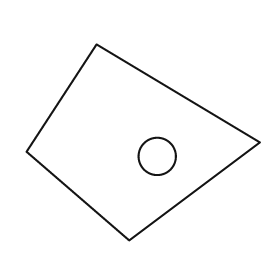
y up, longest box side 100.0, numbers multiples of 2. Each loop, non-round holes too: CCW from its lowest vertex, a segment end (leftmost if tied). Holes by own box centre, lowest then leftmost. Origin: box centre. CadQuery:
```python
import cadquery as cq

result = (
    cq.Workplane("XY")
    .moveTo(-6.0, -42.0)
    .lineTo(50.0, 0.0)
    .lineTo(-20.0, 42.0)
    .lineTo(-50.0, -4.0)
    .close()
    .moveTo(6.0, -6.0)
    .circle(8.0)
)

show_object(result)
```